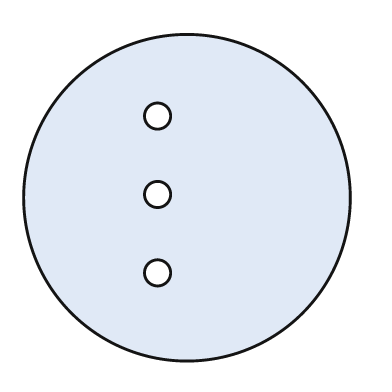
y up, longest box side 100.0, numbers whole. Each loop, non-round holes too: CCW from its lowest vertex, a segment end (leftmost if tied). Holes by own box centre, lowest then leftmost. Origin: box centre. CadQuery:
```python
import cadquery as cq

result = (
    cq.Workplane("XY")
    .moveTo(0.0, 0.0)
    .circle(50.0)
    .moveTo(-9.0, -23.0)
    .circle(4.0)
    .moveTo(-9.0, 1.0)
    .circle(4.0)
    .moveTo(-9.0, 25.0)
    .circle(4.0)
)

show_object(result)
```